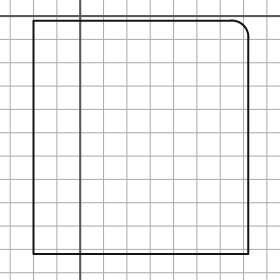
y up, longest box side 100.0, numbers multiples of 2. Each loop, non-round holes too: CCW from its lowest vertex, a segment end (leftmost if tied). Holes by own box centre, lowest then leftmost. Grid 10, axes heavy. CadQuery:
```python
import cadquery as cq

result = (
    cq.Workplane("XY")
    .moveTo(-20.0, -102.0)
    .lineTo(72.0, -102.0)
    .lineTo(72.0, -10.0)
    .threePointArc((70.0, -4.0), (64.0, -2.0))
    .lineTo(-20.0, -2.0)
    .close()
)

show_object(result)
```